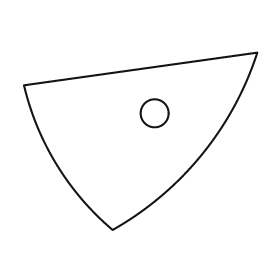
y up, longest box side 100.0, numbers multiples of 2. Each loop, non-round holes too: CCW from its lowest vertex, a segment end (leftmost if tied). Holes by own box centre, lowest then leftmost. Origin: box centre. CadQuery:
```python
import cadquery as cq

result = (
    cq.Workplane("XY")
    .moveTo(-12.0, -38.0)
    .threePointArc((26.0, -6.0), (50.0, 38.0))
    .lineTo(-50.0, 24.0)
    .threePointArc((-36.0, -10.0), (-12.0, -38.0))
    .close()
    .moveTo(6.0, 12.0)
    .circle(6.0)
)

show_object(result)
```